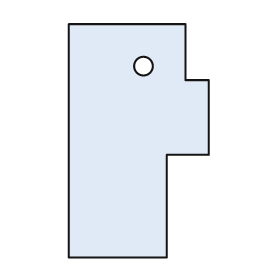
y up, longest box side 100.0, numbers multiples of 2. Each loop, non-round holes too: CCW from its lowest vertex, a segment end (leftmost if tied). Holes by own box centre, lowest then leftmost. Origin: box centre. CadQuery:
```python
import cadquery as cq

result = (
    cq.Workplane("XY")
    .moveTo(-30.0, -50.0)
    .lineTo(12.0, -50.0)
    .lineTo(12.0, -6.0)
    .lineTo(30.0, -6.0)
    .lineTo(30.0, 26.0)
    .lineTo(20.0, 26.0)
    .lineTo(20.0, 50.0)
    .lineTo(-30.0, 50.0)
    .close()
    .moveTo(2.0, 32.0)
    .circle(4.0)
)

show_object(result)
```